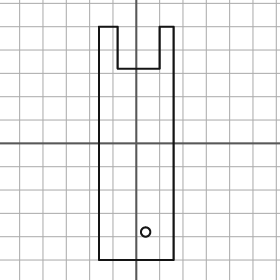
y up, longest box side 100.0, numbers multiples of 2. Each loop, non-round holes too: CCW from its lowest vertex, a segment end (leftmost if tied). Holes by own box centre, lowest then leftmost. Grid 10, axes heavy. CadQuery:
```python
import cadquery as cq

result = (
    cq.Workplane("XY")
    .moveTo(-16.0, -50.0)
    .lineTo(16.0, -50.0)
    .lineTo(16.0, 50.0)
    .lineTo(10.0, 50.0)
    .lineTo(10.0, 32.0)
    .lineTo(-8.0, 32.0)
    .lineTo(-8.0, 50.0)
    .lineTo(-16.0, 50.0)
    .close()
    .moveTo(4.0, -38.0)
    .circle(2.0)
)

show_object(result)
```